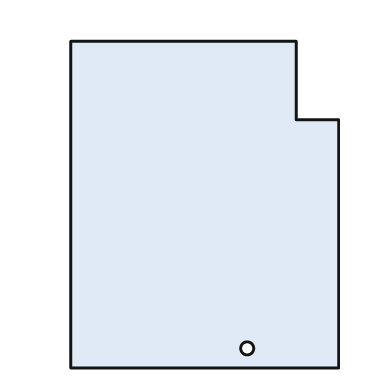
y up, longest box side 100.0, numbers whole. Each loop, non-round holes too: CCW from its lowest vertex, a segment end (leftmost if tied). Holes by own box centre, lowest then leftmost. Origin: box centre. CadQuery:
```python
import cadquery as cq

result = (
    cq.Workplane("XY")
    .moveTo(-41.0, -50.0)
    .lineTo(41.0, -50.0)
    .lineTo(41.0, 26.0)
    .lineTo(28.0, 26.0)
    .lineTo(28.0, 50.0)
    .lineTo(-41.0, 50.0)
    .close()
    .moveTo(13.0, -44.0)
    .circle(2.0)
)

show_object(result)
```